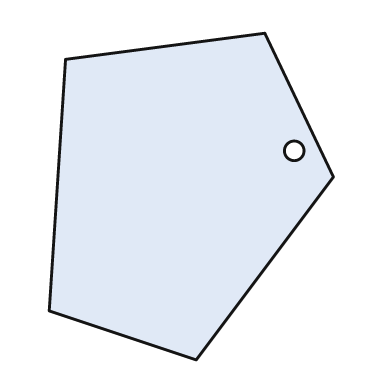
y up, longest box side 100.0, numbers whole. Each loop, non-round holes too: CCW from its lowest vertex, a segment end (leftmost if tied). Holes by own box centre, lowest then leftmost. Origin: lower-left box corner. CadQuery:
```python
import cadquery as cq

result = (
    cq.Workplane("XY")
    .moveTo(45.0, 0.0)
    .lineTo(87.0, 56.0)
    .lineTo(66.0, 100.0)
    .lineTo(5.0, 92.0)
    .lineTo(0.0, 15.0)
    .close()
    .moveTo(75.0, 64.0)
    .circle(3.0)
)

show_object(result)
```